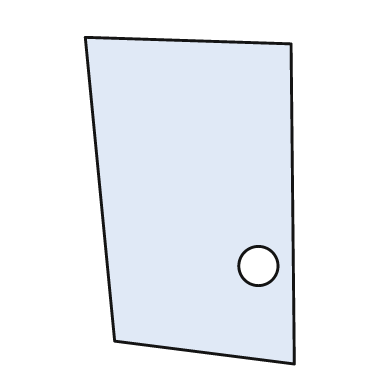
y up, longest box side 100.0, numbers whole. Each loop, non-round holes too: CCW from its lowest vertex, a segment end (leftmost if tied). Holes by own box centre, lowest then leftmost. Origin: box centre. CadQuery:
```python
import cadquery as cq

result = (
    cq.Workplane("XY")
    .moveTo(32.0, -50.0)
    .lineTo(31.0, 48.0)
    .lineTo(-32.0, 50.0)
    .lineTo(-23.0, -43.0)
    .close()
    .moveTo(21.0, -20.0)
    .circle(6.0)
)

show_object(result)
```